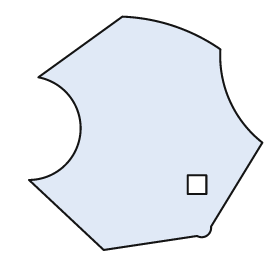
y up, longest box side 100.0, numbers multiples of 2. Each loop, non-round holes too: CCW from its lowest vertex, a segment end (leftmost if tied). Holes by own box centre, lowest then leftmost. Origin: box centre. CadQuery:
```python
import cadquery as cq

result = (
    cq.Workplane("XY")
    .moveTo(-18.0, -50.0)
    .lineTo(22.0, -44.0)
    .threePointArc((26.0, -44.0), (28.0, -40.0))
    .lineTo(50.0, -4.0)
    .threePointArc((36.0, 14.0), (32.0, 36.0))
    .threePointArc((12.0, 46.0), (-10.0, 50.0))
    .lineTo(-46.0, 24.0)
    .threePointArc((-28.0, 0.0), (-50.0, -20.0))
    .close()
    .moveTo(18.0, -26.0)
    .lineTo(26.0, -26.0)
    .lineTo(26.0, -18.0)
    .lineTo(18.0, -18.0)
    .close()
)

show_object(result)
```